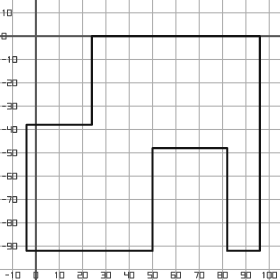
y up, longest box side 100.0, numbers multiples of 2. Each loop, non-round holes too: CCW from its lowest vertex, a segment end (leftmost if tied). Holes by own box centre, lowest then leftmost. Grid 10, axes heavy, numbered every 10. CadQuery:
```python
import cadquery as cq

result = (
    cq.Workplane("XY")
    .moveTo(-4.0, -92.0)
    .lineTo(50.0, -92.0)
    .lineTo(50.0, -48.0)
    .lineTo(82.0, -48.0)
    .lineTo(82.0, -92.0)
    .lineTo(96.0, -92.0)
    .lineTo(96.0, 0.0)
    .lineTo(24.0, 0.0)
    .lineTo(24.0, -38.0)
    .lineTo(-4.0, -38.0)
    .close()
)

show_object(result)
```